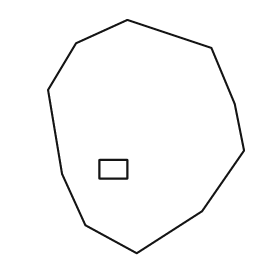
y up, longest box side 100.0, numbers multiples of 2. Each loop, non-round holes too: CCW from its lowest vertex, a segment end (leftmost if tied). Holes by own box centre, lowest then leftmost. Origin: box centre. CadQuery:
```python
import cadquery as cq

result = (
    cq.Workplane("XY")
    .moveTo(-4.0, -50.0)
    .lineTo(24.0, -32.0)
    .lineTo(42.0, -6.0)
    .lineTo(38.0, 14.0)
    .lineTo(28.0, 38.0)
    .lineTo(-8.0, 50.0)
    .lineTo(-30.0, 40.0)
    .lineTo(-42.0, 20.0)
    .lineTo(-36.0, -16.0)
    .lineTo(-26.0, -38.0)
    .close()
    .moveTo(-20.0, -18.0)
    .lineTo(-8.0, -18.0)
    .lineTo(-8.0, -10.0)
    .lineTo(-20.0, -10.0)
    .close()
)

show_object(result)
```